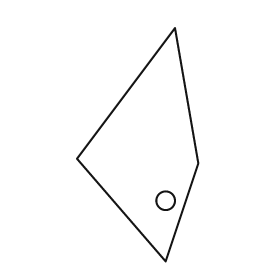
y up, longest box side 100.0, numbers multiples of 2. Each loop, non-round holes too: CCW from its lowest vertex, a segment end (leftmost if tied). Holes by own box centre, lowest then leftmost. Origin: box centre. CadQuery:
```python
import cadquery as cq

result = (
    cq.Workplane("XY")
    .moveTo(12.0, -50.0)
    .lineTo(26.0, -8.0)
    .lineTo(16.0, 50.0)
    .lineTo(-26.0, -6.0)
    .close()
    .moveTo(12.0, -24.0)
    .circle(4.0)
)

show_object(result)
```